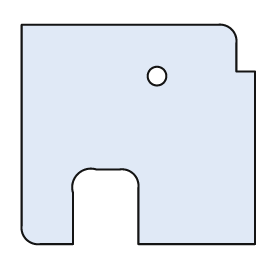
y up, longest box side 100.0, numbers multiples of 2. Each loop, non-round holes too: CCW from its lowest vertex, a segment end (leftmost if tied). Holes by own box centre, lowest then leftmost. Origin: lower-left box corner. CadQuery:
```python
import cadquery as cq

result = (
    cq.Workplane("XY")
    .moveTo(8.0, 0.0)
    .lineTo(22.0, 0.0)
    .lineTo(22.0, 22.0)
    .threePointArc((24.0, 30.0), (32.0, 32.0))
    .lineTo(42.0, 32.0)
    .threePointArc((48.0, 30.0), (50.0, 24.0))
    .lineTo(50.0, 0.0)
    .lineTo(100.0, 0.0)
    .lineTo(100.0, 74.0)
    .lineTo(92.0, 74.0)
    .lineTo(92.0, 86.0)
    .threePointArc((90.0, 92.0), (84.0, 94.0))
    .lineTo(0.0, 94.0)
    .lineTo(0.0, 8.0)
    .threePointArc((2.0, 2.0), (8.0, 0.0))
    .close()
    .moveTo(58.0, 72.0)
    .circle(4.0)
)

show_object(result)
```